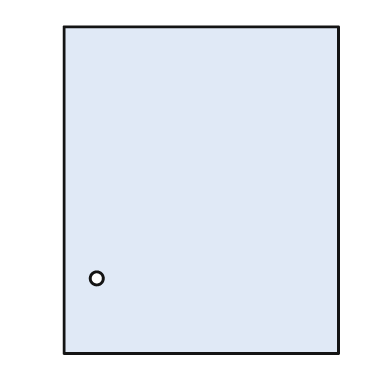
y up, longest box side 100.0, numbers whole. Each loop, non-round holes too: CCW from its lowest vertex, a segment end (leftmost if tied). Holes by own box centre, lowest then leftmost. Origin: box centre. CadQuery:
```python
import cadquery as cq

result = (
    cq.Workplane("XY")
    .moveTo(-42.0, -50.0)
    .lineTo(42.0, -50.0)
    .lineTo(42.0, 50.0)
    .lineTo(-42.0, 50.0)
    .close()
    .moveTo(-32.0, -27.0)
    .circle(2.0)
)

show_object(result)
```